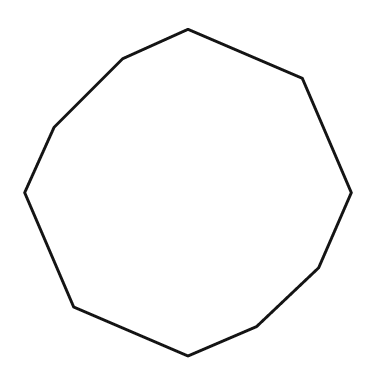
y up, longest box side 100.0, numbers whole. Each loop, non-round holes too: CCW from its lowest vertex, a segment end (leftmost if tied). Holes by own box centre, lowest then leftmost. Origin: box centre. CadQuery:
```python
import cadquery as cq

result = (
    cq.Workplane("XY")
    .moveTo(0.0, -50.0)
    .lineTo(21.0, -41.0)
    .lineTo(40.0, -23.0)
    .lineTo(50.0, 0.0)
    .lineTo(35.0, 35.0)
    .lineTo(0.0, 50.0)
    .lineTo(-20.0, 41.0)
    .lineTo(-41.0, 20.0)
    .lineTo(-50.0, 0.0)
    .lineTo(-35.0, -35.0)
    .close()
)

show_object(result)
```